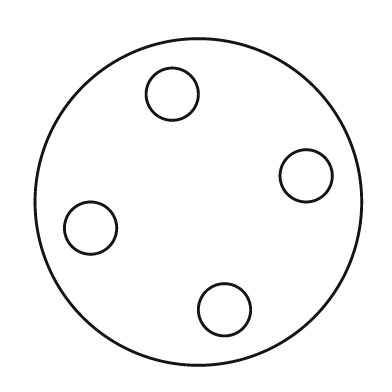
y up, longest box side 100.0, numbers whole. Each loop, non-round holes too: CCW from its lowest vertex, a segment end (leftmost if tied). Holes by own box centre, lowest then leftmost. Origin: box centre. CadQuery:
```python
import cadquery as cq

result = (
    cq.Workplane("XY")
    .moveTo(0.0, 0.0)
    .circle(50.0)
    .moveTo(8.0, -33.0)
    .circle(8.0)
    .moveTo(-33.0, -8.0)
    .circle(8.0)
    .moveTo(33.0, 8.0)
    .circle(8.0)
    .moveTo(-8.0, 33.0)
    .circle(8.0)
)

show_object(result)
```